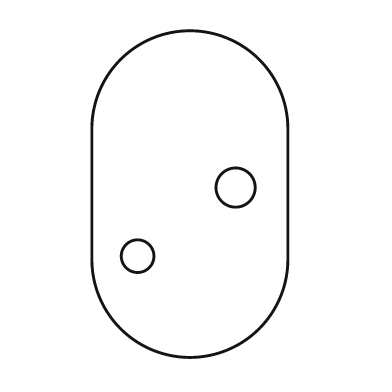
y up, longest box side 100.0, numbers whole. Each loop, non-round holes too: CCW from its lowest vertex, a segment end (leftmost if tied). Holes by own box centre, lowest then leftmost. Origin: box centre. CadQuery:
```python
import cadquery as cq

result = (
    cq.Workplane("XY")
    .moveTo(-30.0, -20.0)
    .threePointArc((0.0, -50.0), (30.0, -20.0))
    .lineTo(30.0, 20.0)
    .threePointArc((0.0, 50.0), (-30.0, 20.0))
    .close()
    .moveTo(-16.0, -19.0)
    .circle(5.0)
    .moveTo(14.0, 2.0)
    .circle(6.0)
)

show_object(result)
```